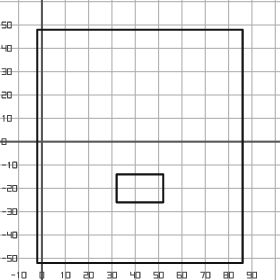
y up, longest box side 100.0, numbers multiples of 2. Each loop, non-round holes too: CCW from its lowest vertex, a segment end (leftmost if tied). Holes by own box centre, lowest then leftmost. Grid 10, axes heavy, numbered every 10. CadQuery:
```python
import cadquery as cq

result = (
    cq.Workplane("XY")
    .moveTo(-2.0, -52.0)
    .lineTo(86.0, -52.0)
    .lineTo(86.0, 48.0)
    .lineTo(-2.0, 48.0)
    .close()
    .moveTo(32.0, -26.0)
    .lineTo(52.0, -26.0)
    .lineTo(52.0, -14.0)
    .lineTo(32.0, -14.0)
    .close()
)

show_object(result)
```